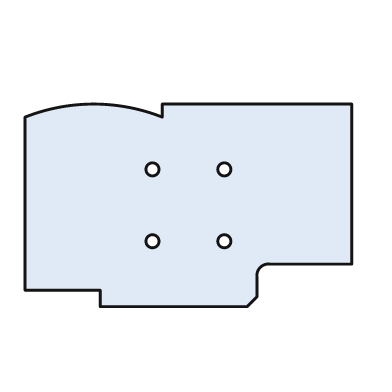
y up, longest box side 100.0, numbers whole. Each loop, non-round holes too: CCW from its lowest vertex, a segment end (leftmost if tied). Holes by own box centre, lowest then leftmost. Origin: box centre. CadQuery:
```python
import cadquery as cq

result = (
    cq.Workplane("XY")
    .moveTo(-27.0, -31.0)
    .lineTo(18.0, -31.0)
    .lineTo(21.0, -28.0)
    .lineTo(21.0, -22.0)
    .threePointArc((22.0, -19.0), (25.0, -18.0))
    .lineTo(50.0, -18.0)
    .lineTo(50.0, 31.0)
    .lineTo(-8.0, 31.0)
    .lineTo(-8.0, 27.0)
    .threePointArc((-29.0, 31.0), (-50.0, 27.0))
    .lineTo(-50.0, -26.0)
    .lineTo(-27.0, -26.0)
    .close()
    .moveTo(-11.0, -11.0)
    .circle(2.0)
    .moveTo(11.0, -11.0)
    .circle(2.0)
    .moveTo(-11.0, 11.0)
    .circle(2.0)
    .moveTo(11.0, 11.0)
    .circle(2.0)
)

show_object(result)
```